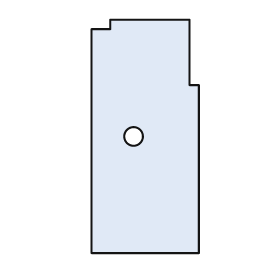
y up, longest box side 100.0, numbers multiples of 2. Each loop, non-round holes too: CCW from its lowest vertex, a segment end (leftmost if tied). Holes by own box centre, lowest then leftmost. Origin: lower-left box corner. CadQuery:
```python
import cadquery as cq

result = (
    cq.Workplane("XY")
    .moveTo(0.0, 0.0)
    .lineTo(46.0, 0.0)
    .lineTo(46.0, 72.0)
    .lineTo(42.0, 72.0)
    .lineTo(42.0, 100.0)
    .lineTo(8.0, 100.0)
    .lineTo(8.0, 96.0)
    .lineTo(0.0, 96.0)
    .close()
    .moveTo(18.0, 50.0)
    .circle(4.0)
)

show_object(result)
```